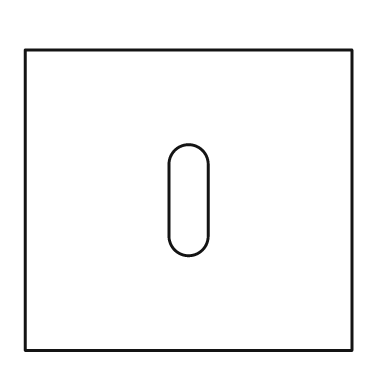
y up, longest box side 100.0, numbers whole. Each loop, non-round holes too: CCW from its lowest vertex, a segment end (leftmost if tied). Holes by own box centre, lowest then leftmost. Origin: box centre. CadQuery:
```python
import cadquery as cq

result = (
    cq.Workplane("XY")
    .moveTo(-50.0, -46.0)
    .lineTo(50.0, -46.0)
    .lineTo(50.0, 46.0)
    .lineTo(-50.0, 46.0)
    .close()
    .moveTo(-6.0, -11.0)
    .threePointArc((0.0, -17.0), (6.0, -11.0))
    .lineTo(6.0, 11.0)
    .threePointArc((0.0, 17.0), (-6.0, 11.0))
    .close()
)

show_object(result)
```